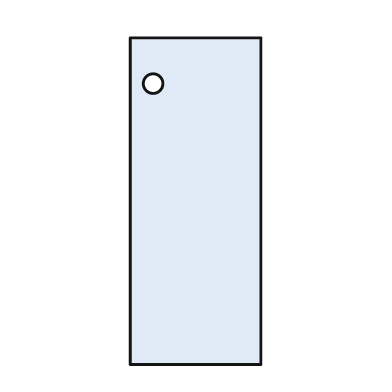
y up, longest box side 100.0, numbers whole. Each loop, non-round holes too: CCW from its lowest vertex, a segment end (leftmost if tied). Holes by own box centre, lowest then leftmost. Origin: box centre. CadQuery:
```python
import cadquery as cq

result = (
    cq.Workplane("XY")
    .moveTo(-20.0, -50.0)
    .lineTo(20.0, -50.0)
    .lineTo(20.0, 50.0)
    .lineTo(-20.0, 50.0)
    .close()
    .moveTo(-13.0, 36.0)
    .circle(3.0)
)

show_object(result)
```